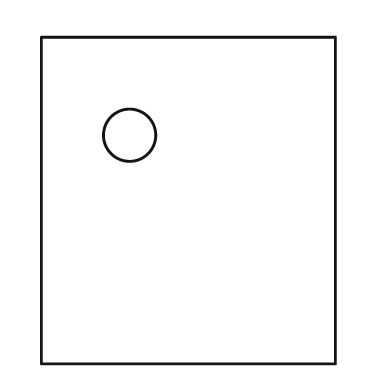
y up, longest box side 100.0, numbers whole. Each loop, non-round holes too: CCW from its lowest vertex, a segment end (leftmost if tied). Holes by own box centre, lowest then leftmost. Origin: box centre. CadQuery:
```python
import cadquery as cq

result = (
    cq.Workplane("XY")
    .moveTo(-45.0, -50.0)
    .lineTo(45.0, -50.0)
    .lineTo(45.0, 50.0)
    .lineTo(-45.0, 50.0)
    .close()
    .moveTo(-18.0, 20.0)
    .circle(8.0)
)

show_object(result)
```